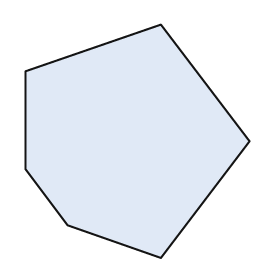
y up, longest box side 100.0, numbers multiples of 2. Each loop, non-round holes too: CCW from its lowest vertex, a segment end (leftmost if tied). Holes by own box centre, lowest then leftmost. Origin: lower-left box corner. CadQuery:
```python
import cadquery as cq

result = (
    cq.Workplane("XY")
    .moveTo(58.0, 0.0)
    .lineTo(96.0, 50.0)
    .lineTo(58.0, 100.0)
    .lineTo(0.0, 80.0)
    .lineTo(0.0, 38.0)
    .lineTo(18.0, 14.0)
    .close()
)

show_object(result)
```